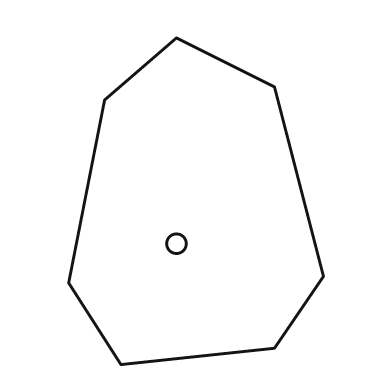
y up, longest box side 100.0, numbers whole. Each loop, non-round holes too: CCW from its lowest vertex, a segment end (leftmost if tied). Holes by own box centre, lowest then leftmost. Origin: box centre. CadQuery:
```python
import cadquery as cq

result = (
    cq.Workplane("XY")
    .moveTo(-23.0, -50.0)
    .lineTo(24.0, -45.0)
    .lineTo(39.0, -23.0)
    .lineTo(24.0, 35.0)
    .lineTo(-6.0, 50.0)
    .lineTo(-28.0, 31.0)
    .lineTo(-39.0, -25.0)
    .close()
    .moveTo(-6.0, -13.0)
    .circle(3.0)
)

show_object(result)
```